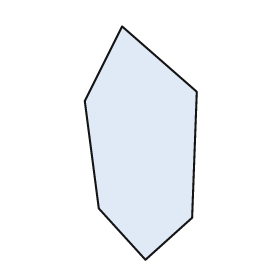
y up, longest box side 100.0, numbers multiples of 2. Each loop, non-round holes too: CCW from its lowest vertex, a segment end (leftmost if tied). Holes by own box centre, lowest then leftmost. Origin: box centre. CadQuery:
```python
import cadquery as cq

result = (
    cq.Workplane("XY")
    .moveTo(2.0, -50.0)
    .lineTo(22.0, -32.0)
    .lineTo(24.0, 22.0)
    .lineTo(-8.0, 50.0)
    .lineTo(-24.0, 18.0)
    .lineTo(-18.0, -28.0)
    .close()
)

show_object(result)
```